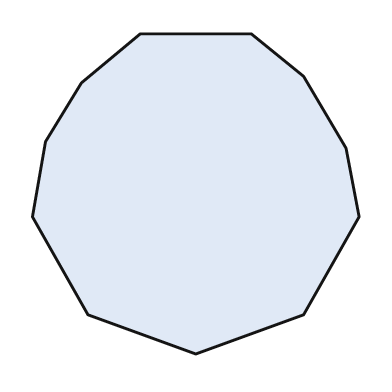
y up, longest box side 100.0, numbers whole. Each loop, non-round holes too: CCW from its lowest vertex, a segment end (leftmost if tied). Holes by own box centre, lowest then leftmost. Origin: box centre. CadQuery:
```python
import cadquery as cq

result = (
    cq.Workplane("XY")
    .moveTo(0.0, -49.0)
    .lineTo(33.0, -37.0)
    .lineTo(50.0, -7.0)
    .lineTo(46.0, 14.0)
    .lineTo(33.0, 36.0)
    .lineTo(17.0, 49.0)
    .lineTo(-17.0, 49.0)
    .lineTo(-35.0, 34.0)
    .lineTo(-46.0, 16.0)
    .lineTo(-50.0, -7.0)
    .lineTo(-33.0, -37.0)
    .close()
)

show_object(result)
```